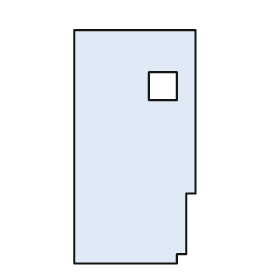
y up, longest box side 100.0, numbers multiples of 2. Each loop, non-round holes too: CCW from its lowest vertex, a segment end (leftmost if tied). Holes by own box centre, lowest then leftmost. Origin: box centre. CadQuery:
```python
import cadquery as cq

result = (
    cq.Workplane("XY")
    .moveTo(-26.0, -50.0)
    .lineTo(18.0, -50.0)
    .lineTo(18.0, -46.0)
    .lineTo(22.0, -46.0)
    .lineTo(22.0, -20.0)
    .lineTo(26.0, -20.0)
    .lineTo(26.0, 50.0)
    .lineTo(-26.0, 50.0)
    .close()
    .moveTo(6.0, 20.0)
    .lineTo(18.0, 20.0)
    .lineTo(18.0, 32.0)
    .lineTo(6.0, 32.0)
    .close()
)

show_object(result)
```